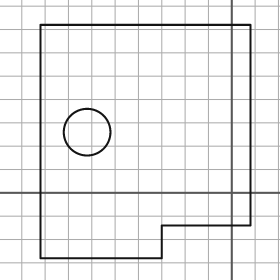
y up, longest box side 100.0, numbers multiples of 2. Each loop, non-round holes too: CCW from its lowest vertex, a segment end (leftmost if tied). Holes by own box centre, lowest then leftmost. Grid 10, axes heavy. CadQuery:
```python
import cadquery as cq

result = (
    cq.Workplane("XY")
    .moveTo(-82.0, -28.0)
    .lineTo(-30.0, -28.0)
    .lineTo(-30.0, -14.0)
    .lineTo(8.0, -14.0)
    .lineTo(8.0, 72.0)
    .lineTo(-82.0, 72.0)
    .close()
    .moveTo(-62.0, 26.0)
    .circle(10.0)
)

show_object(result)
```